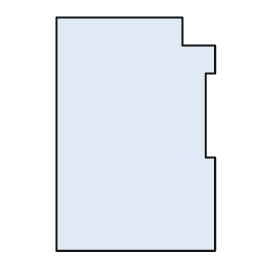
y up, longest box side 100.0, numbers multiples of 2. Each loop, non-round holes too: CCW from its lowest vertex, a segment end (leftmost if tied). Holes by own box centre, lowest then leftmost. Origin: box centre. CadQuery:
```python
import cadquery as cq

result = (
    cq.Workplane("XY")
    .moveTo(-34.0, -50.0)
    .lineTo(34.0, -50.0)
    .lineTo(34.0, -10.0)
    .lineTo(30.0, -10.0)
    .lineTo(30.0, 26.0)
    .lineTo(34.0, 26.0)
    .lineTo(34.0, 38.0)
    .lineTo(20.0, 38.0)
    .lineTo(20.0, 50.0)
    .lineTo(-34.0, 50.0)
    .close()
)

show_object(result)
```